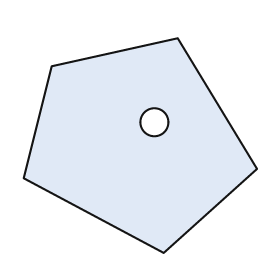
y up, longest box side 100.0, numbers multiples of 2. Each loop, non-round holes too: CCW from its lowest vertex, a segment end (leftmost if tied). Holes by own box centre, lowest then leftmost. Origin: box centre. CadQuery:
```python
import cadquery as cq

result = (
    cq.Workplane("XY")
    .moveTo(10.0, -46.0)
    .lineTo(50.0, -10.0)
    .lineTo(16.0, 46.0)
    .lineTo(-38.0, 34.0)
    .lineTo(-50.0, -14.0)
    .close()
    .moveTo(6.0, 10.0)
    .circle(6.0)
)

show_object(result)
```